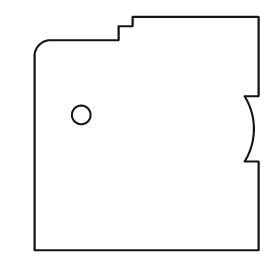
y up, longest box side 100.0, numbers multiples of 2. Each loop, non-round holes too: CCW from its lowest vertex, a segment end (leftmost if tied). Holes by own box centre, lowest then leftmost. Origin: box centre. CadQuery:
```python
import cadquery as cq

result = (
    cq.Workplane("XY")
    .moveTo(-48.0, -50.0)
    .lineTo(48.0, -50.0)
    .lineTo(48.0, -12.0)
    .lineTo(42.0, -12.0)
    .threePointArc((46.0, 2.0), (42.0, 16.0))
    .lineTo(48.0, 16.0)
    .lineTo(48.0, 50.0)
    .lineTo(-6.0, 50.0)
    .lineTo(-6.0, 46.0)
    .lineTo(-12.0, 46.0)
    .lineTo(-12.0, 40.0)
    .lineTo(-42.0, 40.0)
    .threePointArc((-46.0, 38.0), (-48.0, 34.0))
    .close()
    .moveTo(-28.0, 8.0)
    .circle(4.0)
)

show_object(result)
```